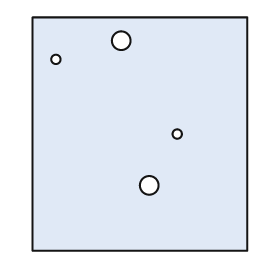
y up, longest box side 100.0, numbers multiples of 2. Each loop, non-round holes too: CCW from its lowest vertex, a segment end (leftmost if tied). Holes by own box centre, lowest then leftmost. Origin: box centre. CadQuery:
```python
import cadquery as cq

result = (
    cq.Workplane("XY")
    .moveTo(-46.0, -50.0)
    .lineTo(46.0, -50.0)
    .lineTo(46.0, 50.0)
    .lineTo(-46.0, 50.0)
    .close()
    .moveTo(4.0, -22.0)
    .circle(4.0)
    .moveTo(16.0, 0.0)
    .circle(2.0)
    .moveTo(-36.0, 32.0)
    .circle(2.0)
    .moveTo(-8.0, 40.0)
    .circle(4.0)
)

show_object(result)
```